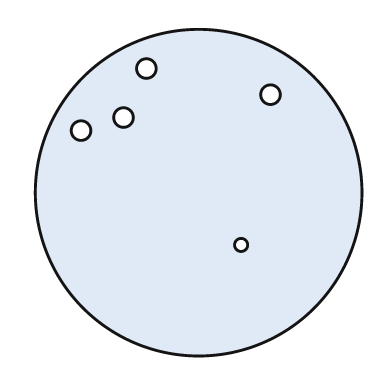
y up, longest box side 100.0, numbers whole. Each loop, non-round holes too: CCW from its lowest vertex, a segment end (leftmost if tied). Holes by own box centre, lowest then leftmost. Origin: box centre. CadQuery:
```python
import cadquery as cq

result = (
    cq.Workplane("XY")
    .moveTo(0.0, 0.0)
    .circle(50.0)
    .moveTo(13.0, -16.0)
    .circle(2.0)
    .moveTo(-36.0, 19.0)
    .circle(3.0)
    .moveTo(-23.0, 23.0)
    .circle(3.0)
    .moveTo(22.0, 30.0)
    .circle(3.0)
    .moveTo(-16.0, 38.0)
    .circle(3.0)
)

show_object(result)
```